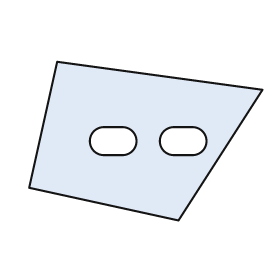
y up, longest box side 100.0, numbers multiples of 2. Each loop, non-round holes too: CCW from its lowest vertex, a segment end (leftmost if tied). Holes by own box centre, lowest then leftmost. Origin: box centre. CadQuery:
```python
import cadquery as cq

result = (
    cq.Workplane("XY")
    .moveTo(14.0, -34.0)
    .lineTo(50.0, 22.0)
    .lineTo(-38.0, 34.0)
    .lineTo(-50.0, -20.0)
    .close()
    .moveTo(-18.0, -6.0)
    .lineTo(-10.0, -6.0)
    .threePointArc((-4.0, 0.0), (-10.0, 6.0))
    .lineTo(-18.0, 6.0)
    .threePointArc((-24.0, 0.0), (-18.0, -6.0))
    .close()
    .moveTo(12.0, -6.0)
    .lineTo(20.0, -6.0)
    .threePointArc((26.0, 0.0), (20.0, 6.0))
    .lineTo(12.0, 6.0)
    .threePointArc((6.0, 0.0), (12.0, -6.0))
    .close()
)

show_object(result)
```